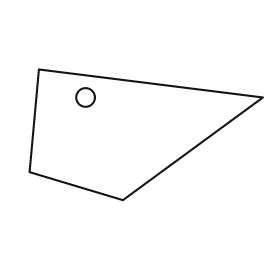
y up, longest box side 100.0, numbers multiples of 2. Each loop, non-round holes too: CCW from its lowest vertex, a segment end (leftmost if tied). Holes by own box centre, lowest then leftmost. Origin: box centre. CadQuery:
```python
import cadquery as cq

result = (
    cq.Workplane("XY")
    .moveTo(-10.0, -28.0)
    .lineTo(50.0, 16.0)
    .lineTo(-46.0, 28.0)
    .lineTo(-50.0, -16.0)
    .close()
    .moveTo(-26.0, 16.0)
    .circle(4.0)
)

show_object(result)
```